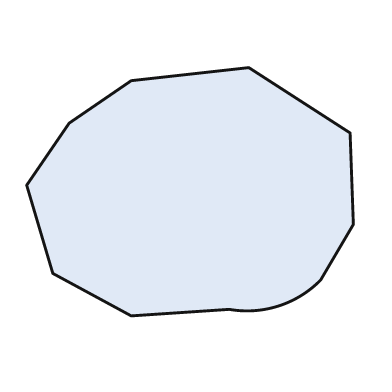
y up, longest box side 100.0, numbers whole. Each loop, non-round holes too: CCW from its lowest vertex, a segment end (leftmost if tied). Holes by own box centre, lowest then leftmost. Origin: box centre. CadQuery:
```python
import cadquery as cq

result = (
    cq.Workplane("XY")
    .moveTo(-18.0, -38.0)
    .lineTo(12.0, -36.0)
    .threePointArc((27.0, -35.0), (40.0, -27.0))
    .lineTo(50.0, -10.0)
    .lineTo(49.0, 18.0)
    .lineTo(18.0, 38.0)
    .lineTo(-18.0, 34.0)
    .lineTo(-37.0, 21.0)
    .lineTo(-50.0, 2.0)
    .lineTo(-42.0, -25.0)
    .close()
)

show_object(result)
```